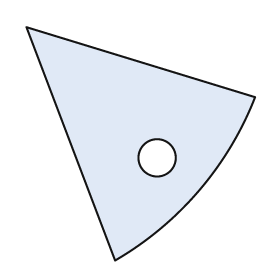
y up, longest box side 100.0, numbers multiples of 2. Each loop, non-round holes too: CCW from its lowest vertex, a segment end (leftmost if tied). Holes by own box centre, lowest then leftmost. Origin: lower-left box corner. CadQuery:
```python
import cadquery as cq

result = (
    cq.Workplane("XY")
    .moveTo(38.0, 0.0)
    .threePointArc((74.0, 30.0), (98.0, 70.0))
    .lineTo(0.0, 100.0)
    .close()
    .moveTo(56.0, 44.0)
    .circle(8.0)
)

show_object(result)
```